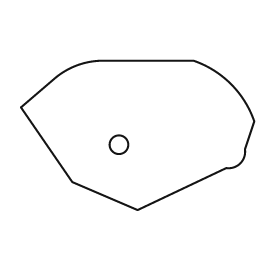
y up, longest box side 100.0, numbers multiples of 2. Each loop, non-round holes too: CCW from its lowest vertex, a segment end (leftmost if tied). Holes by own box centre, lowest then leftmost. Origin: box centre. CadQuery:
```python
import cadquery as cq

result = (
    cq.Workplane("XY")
    .moveTo(0.0, -32.0)
    .lineTo(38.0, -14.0)
    .threePointArc((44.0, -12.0), (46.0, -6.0))
    .lineTo(50.0, 6.0)
    .threePointArc((40.0, 22.0), (24.0, 32.0))
    .lineTo(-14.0, 32.0)
    .threePointArc((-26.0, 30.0), (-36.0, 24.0))
    .lineTo(-50.0, 12.0)
    .lineTo(-28.0, -20.0)
    .close()
    .moveTo(-8.0, -4.0)
    .circle(4.0)
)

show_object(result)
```